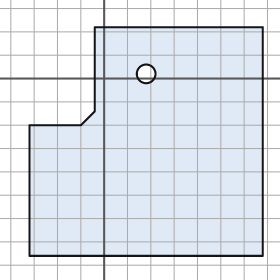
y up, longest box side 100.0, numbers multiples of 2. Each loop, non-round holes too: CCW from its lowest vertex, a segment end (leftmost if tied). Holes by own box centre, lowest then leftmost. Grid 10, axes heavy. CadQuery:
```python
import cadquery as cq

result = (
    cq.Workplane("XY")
    .moveTo(-32.0, -76.0)
    .lineTo(68.0, -76.0)
    .lineTo(68.0, 22.0)
    .lineTo(-4.0, 22.0)
    .lineTo(-4.0, -14.0)
    .lineTo(-10.0, -20.0)
    .lineTo(-32.0, -20.0)
    .close()
    .moveTo(18.0, 2.0)
    .circle(4.0)
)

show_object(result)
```